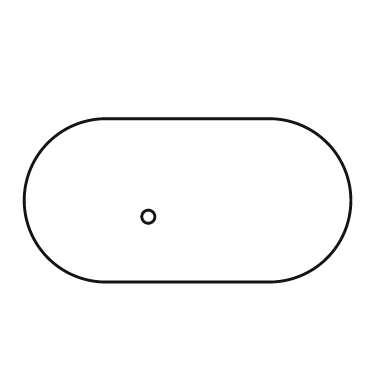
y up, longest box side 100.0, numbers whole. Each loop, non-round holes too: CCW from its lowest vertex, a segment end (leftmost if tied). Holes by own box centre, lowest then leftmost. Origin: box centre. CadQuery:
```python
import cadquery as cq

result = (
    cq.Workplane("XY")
    .moveTo(-25.0, -25.0)
    .lineTo(25.0, -25.0)
    .threePointArc((50.0, 0.0), (25.0, 25.0))
    .lineTo(-25.0, 25.0)
    .threePointArc((-50.0, 0.0), (-25.0, -25.0))
    .close()
    .moveTo(-12.0, -5.0)
    .circle(2.0)
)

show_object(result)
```